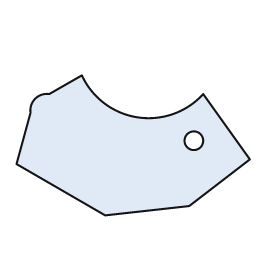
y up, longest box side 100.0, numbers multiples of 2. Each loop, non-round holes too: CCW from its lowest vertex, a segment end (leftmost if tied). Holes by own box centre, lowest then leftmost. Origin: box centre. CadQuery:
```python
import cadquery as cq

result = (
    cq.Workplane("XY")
    .moveTo(-12.0, -30.0)
    .lineTo(24.0, -26.0)
    .lineTo(50.0, -6.0)
    .lineTo(30.0, 22.0)
    .threePointArc((2.0, 12.0), (-22.0, 30.0))
    .lineTo(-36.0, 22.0)
    .threePointArc((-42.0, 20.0), (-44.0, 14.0))
    .lineTo(-50.0, -8.0)
    .close()
    .moveTo(26.0, 2.0)
    .circle(4.0)
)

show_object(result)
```